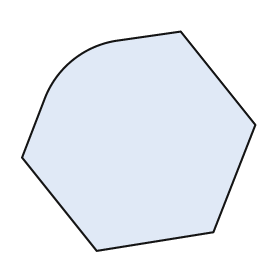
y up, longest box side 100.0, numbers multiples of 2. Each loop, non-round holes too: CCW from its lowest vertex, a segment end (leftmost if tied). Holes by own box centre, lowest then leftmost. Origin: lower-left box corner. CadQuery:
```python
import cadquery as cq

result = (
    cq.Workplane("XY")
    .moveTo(32.0, 0.0)
    .lineTo(82.0, 8.0)
    .lineTo(100.0, 54.0)
    .lineTo(68.0, 94.0)
    .lineTo(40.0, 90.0)
    .threePointArc((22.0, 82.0), (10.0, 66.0))
    .lineTo(0.0, 40.0)
    .close()
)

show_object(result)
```